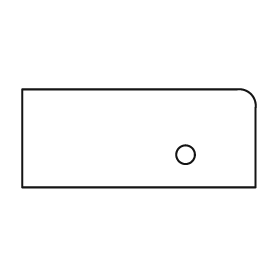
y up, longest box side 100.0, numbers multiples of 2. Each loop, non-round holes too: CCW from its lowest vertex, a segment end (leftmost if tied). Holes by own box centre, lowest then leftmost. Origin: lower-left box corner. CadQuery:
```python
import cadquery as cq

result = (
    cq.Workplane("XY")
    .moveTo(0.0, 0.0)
    .lineTo(100.0, 0.0)
    .lineTo(100.0, 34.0)
    .threePointArc((98.0, 40.0), (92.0, 42.0))
    .lineTo(0.0, 42.0)
    .close()
    .moveTo(70.0, 14.0)
    .circle(4.0)
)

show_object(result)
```